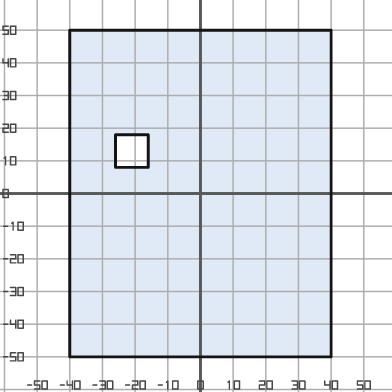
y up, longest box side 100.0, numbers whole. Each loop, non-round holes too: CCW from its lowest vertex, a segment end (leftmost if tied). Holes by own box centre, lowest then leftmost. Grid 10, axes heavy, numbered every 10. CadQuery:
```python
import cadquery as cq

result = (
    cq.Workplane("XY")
    .moveTo(-40.0, -50.0)
    .lineTo(40.0, -50.0)
    .lineTo(40.0, 50.0)
    .lineTo(-40.0, 50.0)
    .close()
    .moveTo(-26.0, 8.0)
    .lineTo(-16.0, 8.0)
    .lineTo(-16.0, 18.0)
    .lineTo(-26.0, 18.0)
    .close()
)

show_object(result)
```